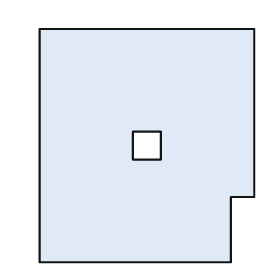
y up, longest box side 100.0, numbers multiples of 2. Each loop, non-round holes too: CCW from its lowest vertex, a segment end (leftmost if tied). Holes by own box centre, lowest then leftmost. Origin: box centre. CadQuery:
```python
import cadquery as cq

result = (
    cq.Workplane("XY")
    .moveTo(-46.0, -50.0)
    .lineTo(36.0, -50.0)
    .lineTo(36.0, -22.0)
    .lineTo(46.0, -22.0)
    .lineTo(46.0, 50.0)
    .lineTo(-46.0, 50.0)
    .close()
    .moveTo(-6.0, -6.0)
    .lineTo(6.0, -6.0)
    .lineTo(6.0, 6.0)
    .lineTo(-6.0, 6.0)
    .close()
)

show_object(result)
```